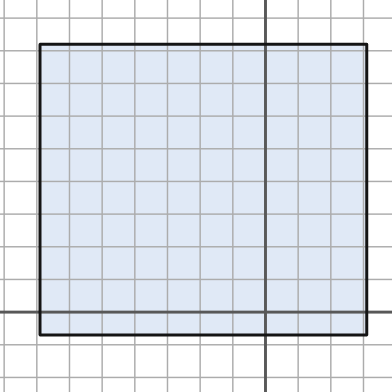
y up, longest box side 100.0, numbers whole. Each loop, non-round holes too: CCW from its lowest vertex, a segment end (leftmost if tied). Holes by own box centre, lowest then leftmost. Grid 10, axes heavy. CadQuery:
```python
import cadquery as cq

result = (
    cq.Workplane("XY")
    .moveTo(-69.0, -7.0)
    .lineTo(31.0, -7.0)
    .lineTo(31.0, 82.0)
    .lineTo(-69.0, 82.0)
    .close()
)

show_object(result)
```